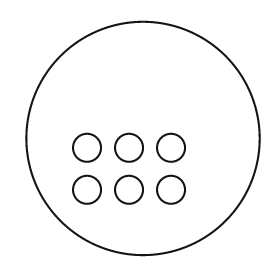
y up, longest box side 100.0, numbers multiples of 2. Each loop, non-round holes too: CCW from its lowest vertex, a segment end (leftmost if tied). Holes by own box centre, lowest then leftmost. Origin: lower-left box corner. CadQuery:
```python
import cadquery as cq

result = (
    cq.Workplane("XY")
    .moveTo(50.0, 50.0)
    .circle(50.0)
    .moveTo(26.0, 28.0)
    .circle(6.0)
    .moveTo(44.0, 28.0)
    .circle(6.0)
    .moveTo(62.0, 28.0)
    .circle(6.0)
    .moveTo(26.0, 46.0)
    .circle(6.0)
    .moveTo(44.0, 46.0)
    .circle(6.0)
    .moveTo(62.0, 46.0)
    .circle(6.0)
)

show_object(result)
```